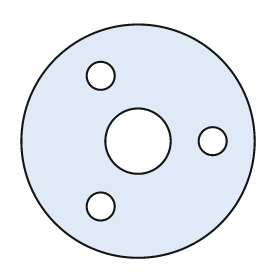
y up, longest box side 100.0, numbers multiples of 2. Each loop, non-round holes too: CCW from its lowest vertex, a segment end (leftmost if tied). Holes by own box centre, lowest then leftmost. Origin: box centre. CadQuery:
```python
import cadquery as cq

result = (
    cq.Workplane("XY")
    .moveTo(0.0, 0.0)
    .circle(50.0)
    .moveTo(-16.0, -28.0)
    .circle(6.0)
    .moveTo(0.0, 0.0)
    .circle(14.0)
    .moveTo(32.0, 0.0)
    .circle(6.0)
    .moveTo(-16.0, 28.0)
    .circle(6.0)
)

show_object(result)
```